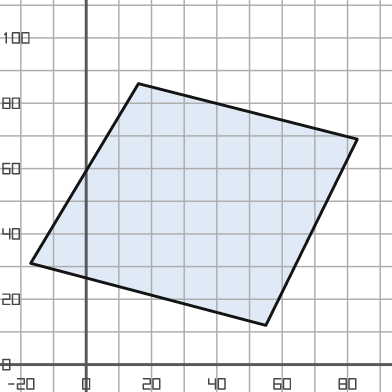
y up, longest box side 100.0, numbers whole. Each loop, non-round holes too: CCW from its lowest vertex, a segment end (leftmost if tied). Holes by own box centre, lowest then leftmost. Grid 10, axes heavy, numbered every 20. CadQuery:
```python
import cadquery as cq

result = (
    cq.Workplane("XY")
    .moveTo(55.0, 12.0)
    .lineTo(83.0, 69.0)
    .lineTo(16.0, 86.0)
    .lineTo(-17.0, 31.0)
    .close()
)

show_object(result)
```